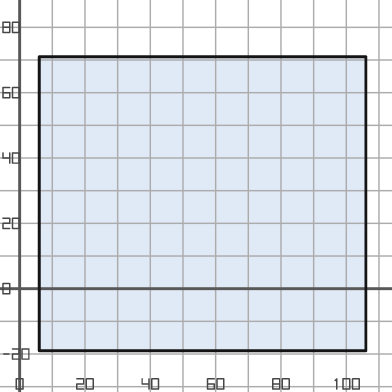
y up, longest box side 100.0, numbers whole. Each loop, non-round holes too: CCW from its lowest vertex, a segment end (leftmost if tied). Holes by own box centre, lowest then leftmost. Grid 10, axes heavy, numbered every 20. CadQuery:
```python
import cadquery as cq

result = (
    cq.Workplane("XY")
    .moveTo(6.0, -19.0)
    .lineTo(106.0, -19.0)
    .lineTo(106.0, 71.0)
    .lineTo(6.0, 71.0)
    .close()
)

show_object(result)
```